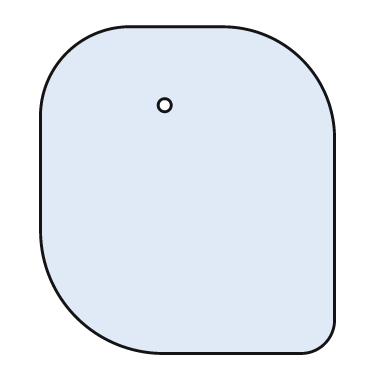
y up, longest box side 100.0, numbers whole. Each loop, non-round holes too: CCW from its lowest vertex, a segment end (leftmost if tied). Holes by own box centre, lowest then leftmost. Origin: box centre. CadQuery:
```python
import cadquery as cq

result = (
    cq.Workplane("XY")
    .moveTo(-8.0, -50.0)
    .lineTo(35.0, -50.0)
    .threePointArc((42.0, -47.0), (45.0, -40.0))
    .lineTo(45.0, 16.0)
    .threePointArc((35.0, 40.0), (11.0, 50.0))
    .lineTo(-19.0, 50.0)
    .threePointArc((-37.0, 42.0), (-45.0, 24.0))
    .lineTo(-45.0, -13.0)
    .threePointArc((-34.0, -39.0), (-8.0, -50.0))
    .close()
    .moveTo(-7.0, 26.0)
    .circle(2.0)
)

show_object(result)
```